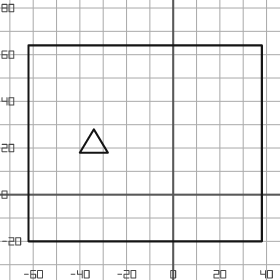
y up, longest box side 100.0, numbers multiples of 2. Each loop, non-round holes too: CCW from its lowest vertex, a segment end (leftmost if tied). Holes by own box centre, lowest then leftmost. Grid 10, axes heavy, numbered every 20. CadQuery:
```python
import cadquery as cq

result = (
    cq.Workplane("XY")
    .moveTo(-62.0, -20.0)
    .lineTo(38.0, -20.0)
    .lineTo(38.0, 64.0)
    .lineTo(-62.0, 64.0)
    .close()
    .moveTo(-40.0, 18.0)
    .lineTo(-28.0, 18.0)
    .lineTo(-34.0, 28.0)
    .close()
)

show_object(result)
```